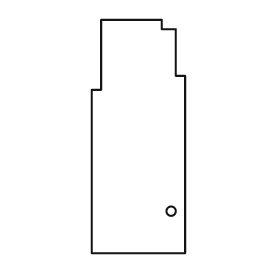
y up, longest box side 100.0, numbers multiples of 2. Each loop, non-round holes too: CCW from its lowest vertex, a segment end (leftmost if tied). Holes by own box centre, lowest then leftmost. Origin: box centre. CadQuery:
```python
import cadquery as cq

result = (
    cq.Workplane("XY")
    .moveTo(-20.0, -50.0)
    .lineTo(20.0, -50.0)
    .lineTo(20.0, 26.0)
    .lineTo(16.0, 26.0)
    .lineTo(16.0, 46.0)
    .lineTo(10.0, 46.0)
    .lineTo(10.0, 50.0)
    .lineTo(-16.0, 50.0)
    .lineTo(-16.0, 20.0)
    .lineTo(-20.0, 20.0)
    .close()
    .moveTo(14.0, -32.0)
    .circle(2.0)
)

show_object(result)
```